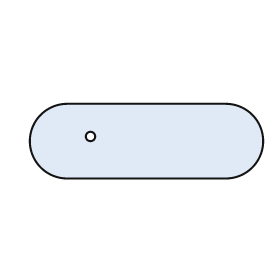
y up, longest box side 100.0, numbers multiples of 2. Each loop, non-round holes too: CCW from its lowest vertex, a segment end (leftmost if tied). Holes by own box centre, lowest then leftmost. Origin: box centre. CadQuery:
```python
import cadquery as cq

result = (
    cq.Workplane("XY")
    .moveTo(-34.0, -16.0)
    .lineTo(34.0, -16.0)
    .threePointArc((50.0, 0.0), (34.0, 16.0))
    .lineTo(-34.0, 16.0)
    .threePointArc((-50.0, 0.0), (-34.0, -16.0))
    .close()
    .moveTo(-24.0, 2.0)
    .circle(2.0)
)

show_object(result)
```